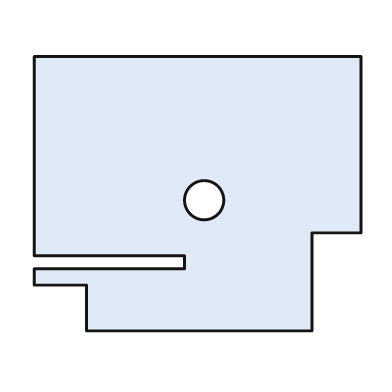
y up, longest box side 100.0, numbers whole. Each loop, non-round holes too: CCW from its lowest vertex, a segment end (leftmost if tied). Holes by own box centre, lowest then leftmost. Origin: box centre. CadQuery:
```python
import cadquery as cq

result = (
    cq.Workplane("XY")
    .moveTo(-34.0, -42.0)
    .lineTo(35.0, -42.0)
    .lineTo(35.0, -12.0)
    .lineTo(50.0, -12.0)
    .lineTo(50.0, 42.0)
    .lineTo(-50.0, 42.0)
    .lineTo(-50.0, -19.0)
    .lineTo(-4.0, -19.0)
    .lineTo(-4.0, -23.0)
    .lineTo(-50.0, -23.0)
    .lineTo(-50.0, -28.0)
    .lineTo(-34.0, -28.0)
    .close()
    .moveTo(2.0, -2.0)
    .circle(6.0)
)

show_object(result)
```